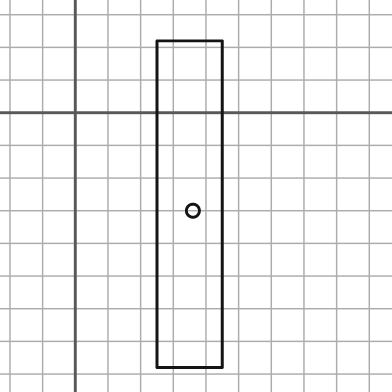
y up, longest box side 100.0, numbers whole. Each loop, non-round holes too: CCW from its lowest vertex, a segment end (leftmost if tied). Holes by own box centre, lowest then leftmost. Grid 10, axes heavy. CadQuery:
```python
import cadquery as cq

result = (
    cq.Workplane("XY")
    .moveTo(25.0, -78.0)
    .lineTo(45.0, -78.0)
    .lineTo(45.0, 22.0)
    .lineTo(25.0, 22.0)
    .close()
    .moveTo(36.0, -30.0)
    .circle(2.0)
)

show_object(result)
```